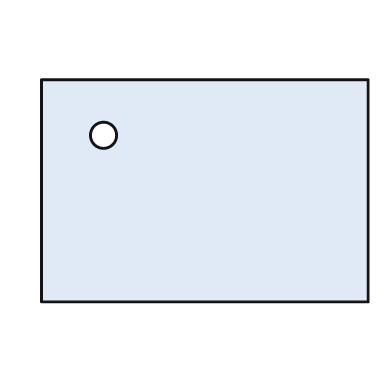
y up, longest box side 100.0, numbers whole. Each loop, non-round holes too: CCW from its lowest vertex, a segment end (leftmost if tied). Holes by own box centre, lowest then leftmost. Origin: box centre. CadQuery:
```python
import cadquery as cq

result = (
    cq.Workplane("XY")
    .moveTo(-50.0, -34.0)
    .lineTo(50.0, -34.0)
    .lineTo(50.0, 34.0)
    .lineTo(-50.0, 34.0)
    .close()
    .moveTo(-31.0, 17.0)
    .circle(4.0)
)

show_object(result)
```